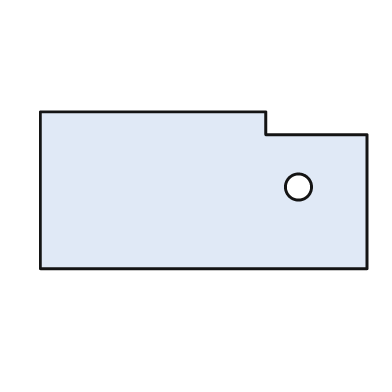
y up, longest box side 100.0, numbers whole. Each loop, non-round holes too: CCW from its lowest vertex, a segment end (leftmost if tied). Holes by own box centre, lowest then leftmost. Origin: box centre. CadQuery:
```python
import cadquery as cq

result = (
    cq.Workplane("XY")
    .moveTo(-50.0, -24.0)
    .lineTo(50.0, -24.0)
    .lineTo(50.0, 17.0)
    .lineTo(19.0, 17.0)
    .lineTo(19.0, 24.0)
    .lineTo(-50.0, 24.0)
    .close()
    .moveTo(29.0, 1.0)
    .circle(4.0)
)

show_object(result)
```